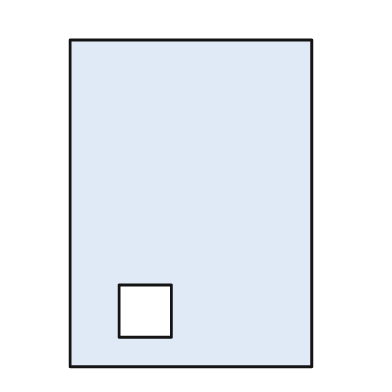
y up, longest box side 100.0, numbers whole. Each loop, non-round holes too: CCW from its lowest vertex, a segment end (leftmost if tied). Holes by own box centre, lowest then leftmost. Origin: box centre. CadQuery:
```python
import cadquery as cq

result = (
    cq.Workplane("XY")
    .moveTo(-37.0, -50.0)
    .lineTo(37.0, -50.0)
    .lineTo(37.0, 50.0)
    .lineTo(-37.0, 50.0)
    .close()
    .moveTo(-22.0, -41.0)
    .lineTo(-6.0, -41.0)
    .lineTo(-6.0, -25.0)
    .lineTo(-22.0, -25.0)
    .close()
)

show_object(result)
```